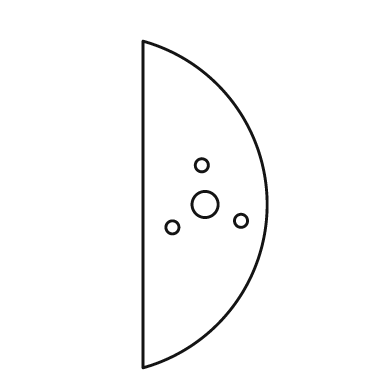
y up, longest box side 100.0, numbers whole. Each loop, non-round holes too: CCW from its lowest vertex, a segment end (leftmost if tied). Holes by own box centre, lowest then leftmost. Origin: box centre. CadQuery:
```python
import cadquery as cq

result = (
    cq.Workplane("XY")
    .moveTo(-19.0, -50.0)
    .threePointArc((19.0, 0.0), (-19.0, 50.0))
    .close()
    .moveTo(-10.0, -7.0)
    .circle(2.0)
    .moveTo(11.0, -5.0)
    .circle(2.0)
    .moveTo(0.0, 0.0)
    .circle(4.0)
    .moveTo(-1.0, 12.0)
    .circle(2.0)
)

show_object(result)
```